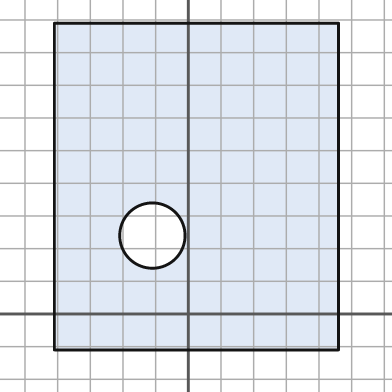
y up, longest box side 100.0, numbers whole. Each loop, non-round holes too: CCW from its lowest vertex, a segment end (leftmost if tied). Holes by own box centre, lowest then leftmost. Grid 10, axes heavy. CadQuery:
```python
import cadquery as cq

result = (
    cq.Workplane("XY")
    .moveTo(-41.0, -11.0)
    .lineTo(46.0, -11.0)
    .lineTo(46.0, 89.0)
    .lineTo(-41.0, 89.0)
    .close()
    .moveTo(-11.0, 24.0)
    .circle(10.0)
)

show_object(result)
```